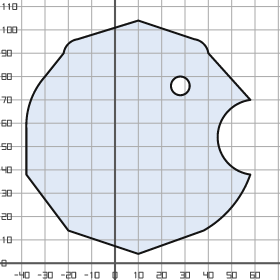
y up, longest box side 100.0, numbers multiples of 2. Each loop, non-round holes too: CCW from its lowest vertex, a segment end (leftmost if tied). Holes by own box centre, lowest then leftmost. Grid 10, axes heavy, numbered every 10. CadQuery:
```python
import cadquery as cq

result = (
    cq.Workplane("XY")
    .moveTo(10.0, 4.0)
    .lineTo(38.0, 14.0)
    .threePointArc((50.0, 24.0), (58.0, 38.0))
    .threePointArc((44.0, 54.0), (58.0, 70.0))
    .lineTo(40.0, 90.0)
    .threePointArc((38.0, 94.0), (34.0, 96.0))
    .lineTo(10.0, 104.0)
    .lineTo(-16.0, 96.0)
    .threePointArc((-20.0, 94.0), (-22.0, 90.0))
    .lineTo(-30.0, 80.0)
    .threePointArc((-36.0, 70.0), (-38.0, 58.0))
    .lineTo(-38.0, 38.0)
    .lineTo(-20.0, 14.0)
    .close()
    .moveTo(28.0, 76.0)
    .circle(4.0)
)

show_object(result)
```